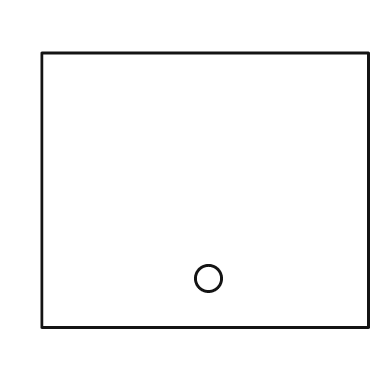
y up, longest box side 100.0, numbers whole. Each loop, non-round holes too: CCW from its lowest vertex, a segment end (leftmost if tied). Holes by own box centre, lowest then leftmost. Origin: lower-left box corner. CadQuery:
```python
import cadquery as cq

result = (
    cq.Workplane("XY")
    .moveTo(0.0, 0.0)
    .lineTo(100.0, 0.0)
    .lineTo(100.0, 84.0)
    .lineTo(0.0, 84.0)
    .close()
    .moveTo(51.0, 15.0)
    .circle(4.0)
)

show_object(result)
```